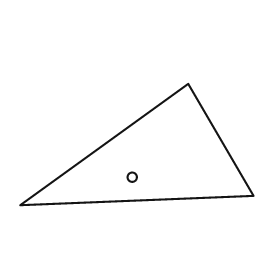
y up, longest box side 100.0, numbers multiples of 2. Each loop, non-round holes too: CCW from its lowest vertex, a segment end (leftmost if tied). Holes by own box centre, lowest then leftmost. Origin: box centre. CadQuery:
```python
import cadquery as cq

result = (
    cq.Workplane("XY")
    .moveTo(-50.0, -26.0)
    .lineTo(50.0, -22.0)
    .lineTo(22.0, 26.0)
    .close()
    .moveTo(-2.0, -14.0)
    .circle(2.0)
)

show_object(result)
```